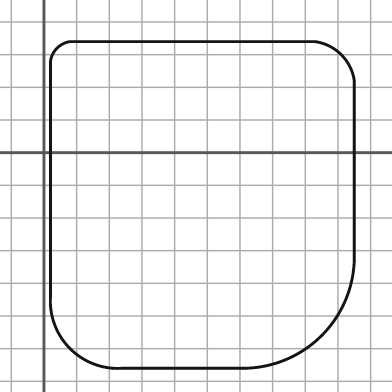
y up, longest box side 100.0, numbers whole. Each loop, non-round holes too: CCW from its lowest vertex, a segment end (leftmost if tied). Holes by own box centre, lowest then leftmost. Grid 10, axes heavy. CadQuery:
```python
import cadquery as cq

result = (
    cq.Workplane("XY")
    .moveTo(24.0, -66.0)
    .lineTo(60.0, -66.0)
    .threePointArc((85.0, -56.0), (95.0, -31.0))
    .lineTo(95.0, 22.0)
    .threePointArc((91.0, 30.0), (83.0, 34.0))
    .lineTo(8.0, 34.0)
    .threePointArc((4.0, 32.0), (2.0, 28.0))
    .lineTo(2.0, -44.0)
    .threePointArc((8.0, -60.0), (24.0, -66.0))
    .close()
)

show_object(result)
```